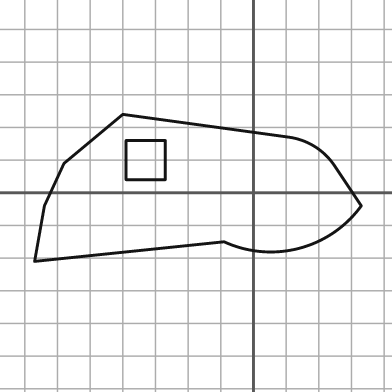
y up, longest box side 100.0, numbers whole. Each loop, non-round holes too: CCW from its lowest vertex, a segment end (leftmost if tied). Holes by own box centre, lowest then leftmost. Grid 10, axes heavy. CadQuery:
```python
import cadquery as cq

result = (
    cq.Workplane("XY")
    .moveTo(-67.0, -21.0)
    .lineTo(-9.0, -15.0)
    .threePointArc((14.0, -17.0), (33.0, -4.0))
    .lineTo(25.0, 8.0)
    .threePointArc((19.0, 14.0), (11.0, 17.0))
    .lineTo(-40.0, 24.0)
    .lineTo(-58.0, 9.0)
    .lineTo(-64.0, -4.0)
    .close()
    .moveTo(-39.0, 4.0)
    .lineTo(-27.0, 4.0)
    .lineTo(-27.0, 16.0)
    .lineTo(-39.0, 16.0)
    .close()
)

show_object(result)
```